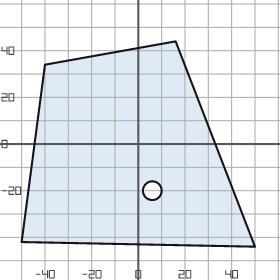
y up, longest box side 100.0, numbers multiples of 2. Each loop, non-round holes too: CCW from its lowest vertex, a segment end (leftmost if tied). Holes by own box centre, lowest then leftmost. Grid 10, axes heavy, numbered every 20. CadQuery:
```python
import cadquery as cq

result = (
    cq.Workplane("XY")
    .moveTo(50.0, -44.0)
    .lineTo(16.0, 44.0)
    .lineTo(-40.0, 34.0)
    .lineTo(-50.0, -42.0)
    .close()
    .moveTo(6.0, -20.0)
    .circle(4.0)
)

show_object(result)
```